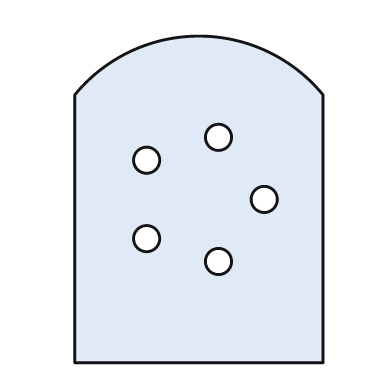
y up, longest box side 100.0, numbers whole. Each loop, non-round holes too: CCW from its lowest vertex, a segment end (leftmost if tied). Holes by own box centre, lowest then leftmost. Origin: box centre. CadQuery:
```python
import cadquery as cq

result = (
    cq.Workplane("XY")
    .moveTo(-38.0, -50.0)
    .lineTo(38.0, -50.0)
    .lineTo(38.0, 32.0)
    .threePointArc((0.0, 50.0), (-38.0, 32.0))
    .close()
    .moveTo(6.0, -19.0)
    .circle(4.0)
    .moveTo(-16.0, -12.0)
    .circle(4.0)
    .moveTo(20.0, 0.0)
    .circle(4.0)
    .moveTo(-16.0, 12.0)
    .circle(4.0)
    .moveTo(6.0, 19.0)
    .circle(4.0)
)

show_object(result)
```